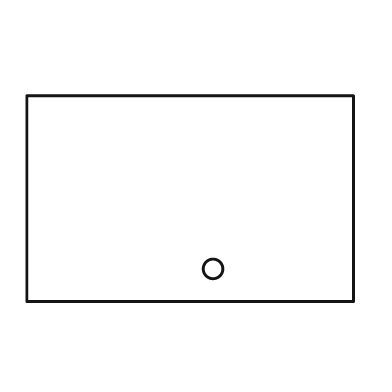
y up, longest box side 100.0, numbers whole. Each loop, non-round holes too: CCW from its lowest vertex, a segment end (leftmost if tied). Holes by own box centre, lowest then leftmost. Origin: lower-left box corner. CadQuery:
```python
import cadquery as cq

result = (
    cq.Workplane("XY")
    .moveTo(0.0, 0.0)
    .lineTo(100.0, 0.0)
    .lineTo(100.0, 63.0)
    .lineTo(0.0, 63.0)
    .close()
    .moveTo(57.0, 10.0)
    .circle(3.0)
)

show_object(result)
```